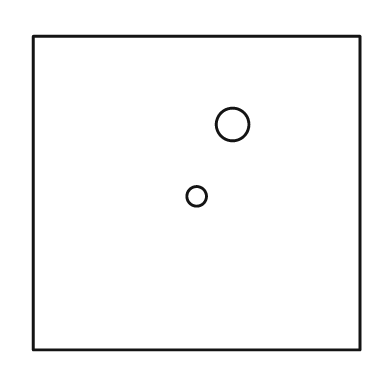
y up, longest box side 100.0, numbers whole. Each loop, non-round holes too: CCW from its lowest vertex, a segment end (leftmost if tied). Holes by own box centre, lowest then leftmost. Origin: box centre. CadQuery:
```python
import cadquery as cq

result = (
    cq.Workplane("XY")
    .moveTo(-50.0, -48.0)
    .lineTo(50.0, -48.0)
    .lineTo(50.0, 48.0)
    .lineTo(-50.0, 48.0)
    .close()
    .moveTo(0.0, -1.0)
    .circle(3.0)
    .moveTo(11.0, 21.0)
    .circle(5.0)
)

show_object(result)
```